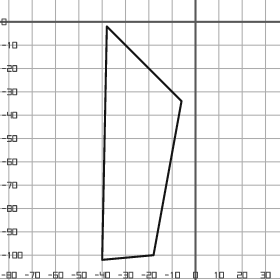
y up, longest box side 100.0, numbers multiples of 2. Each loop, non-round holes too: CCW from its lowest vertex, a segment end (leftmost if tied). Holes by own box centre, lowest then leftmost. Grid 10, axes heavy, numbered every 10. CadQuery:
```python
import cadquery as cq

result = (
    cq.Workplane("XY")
    .moveTo(-40.0, -102.0)
    .lineTo(-18.0, -100.0)
    .lineTo(-6.0, -34.0)
    .lineTo(-38.0, -2.0)
    .close()
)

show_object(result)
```